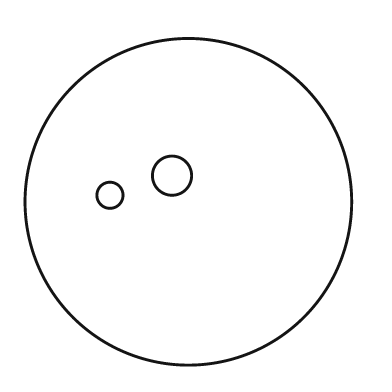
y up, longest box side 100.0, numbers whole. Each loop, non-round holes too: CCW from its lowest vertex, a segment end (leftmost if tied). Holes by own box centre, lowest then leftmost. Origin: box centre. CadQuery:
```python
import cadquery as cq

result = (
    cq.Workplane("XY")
    .moveTo(0.0, 0.0)
    .circle(50.0)
    .moveTo(-24.0, 2.0)
    .circle(4.0)
    .moveTo(-5.0, 8.0)
    .circle(6.0)
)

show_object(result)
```